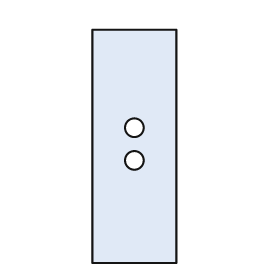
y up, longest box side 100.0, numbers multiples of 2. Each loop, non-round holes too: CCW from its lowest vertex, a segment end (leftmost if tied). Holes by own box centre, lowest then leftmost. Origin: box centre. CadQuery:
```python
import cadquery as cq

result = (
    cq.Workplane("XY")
    .moveTo(-18.0, -50.0)
    .lineTo(18.0, -50.0)
    .lineTo(18.0, 50.0)
    .lineTo(-18.0, 50.0)
    .close()
    .moveTo(0.0, -6.0)
    .circle(4.0)
    .moveTo(0.0, 8.0)
    .circle(4.0)
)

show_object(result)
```